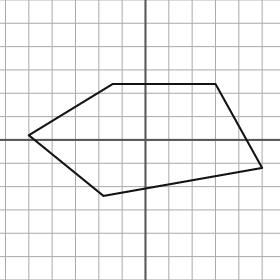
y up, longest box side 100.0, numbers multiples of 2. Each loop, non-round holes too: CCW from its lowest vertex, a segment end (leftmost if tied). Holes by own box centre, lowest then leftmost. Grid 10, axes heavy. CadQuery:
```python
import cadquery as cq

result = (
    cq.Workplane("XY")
    .moveTo(-18.0, -24.0)
    .lineTo(50.0, -12.0)
    .lineTo(30.0, 24.0)
    .lineTo(-14.0, 24.0)
    .lineTo(-50.0, 2.0)
    .close()
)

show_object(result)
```